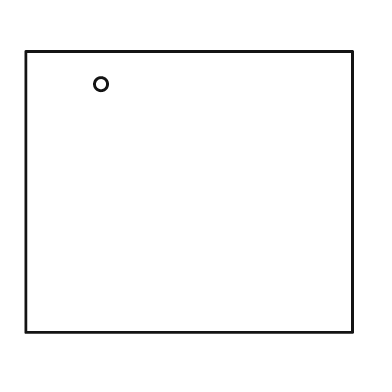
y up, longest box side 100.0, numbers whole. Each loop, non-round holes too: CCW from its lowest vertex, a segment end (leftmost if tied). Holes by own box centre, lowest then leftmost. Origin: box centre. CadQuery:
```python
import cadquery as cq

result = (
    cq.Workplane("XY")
    .moveTo(-50.0, -43.0)
    .lineTo(50.0, -43.0)
    .lineTo(50.0, 43.0)
    .lineTo(-50.0, 43.0)
    .close()
    .moveTo(-27.0, 33.0)
    .circle(2.0)
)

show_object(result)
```